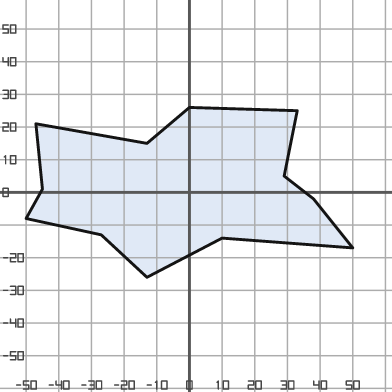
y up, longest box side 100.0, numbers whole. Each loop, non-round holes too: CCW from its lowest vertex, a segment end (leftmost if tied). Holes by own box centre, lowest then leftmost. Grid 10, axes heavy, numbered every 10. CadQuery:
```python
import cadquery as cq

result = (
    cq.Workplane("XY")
    .moveTo(-13.0, -26.0)
    .lineTo(10.0, -14.0)
    .lineTo(50.0, -17.0)
    .lineTo(38.0, -2.0)
    .lineTo(29.0, 5.0)
    .lineTo(33.0, 25.0)
    .lineTo(0.0, 26.0)
    .lineTo(-13.0, 15.0)
    .lineTo(-47.0, 21.0)
    .lineTo(-45.0, 1.0)
    .lineTo(-50.0, -8.0)
    .lineTo(-27.0, -13.0)
    .close()
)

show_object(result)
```